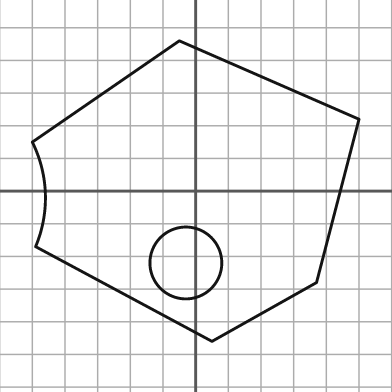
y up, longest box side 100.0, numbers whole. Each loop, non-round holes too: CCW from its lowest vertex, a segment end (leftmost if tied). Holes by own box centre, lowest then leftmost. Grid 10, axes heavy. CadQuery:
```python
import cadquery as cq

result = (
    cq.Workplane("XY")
    .moveTo(5.0, -46.0)
    .lineTo(37.0, -28.0)
    .lineTo(50.0, 22.0)
    .lineTo(-5.0, 46.0)
    .lineTo(-50.0, 15.0)
    .threePointArc((-46.0, -1.0), (-49.0, -17.0))
    .close()
    .moveTo(-3.0, -22.0)
    .circle(11.0)
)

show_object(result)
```